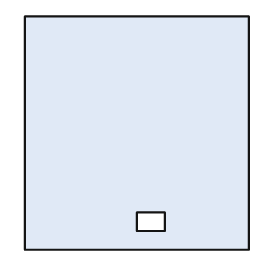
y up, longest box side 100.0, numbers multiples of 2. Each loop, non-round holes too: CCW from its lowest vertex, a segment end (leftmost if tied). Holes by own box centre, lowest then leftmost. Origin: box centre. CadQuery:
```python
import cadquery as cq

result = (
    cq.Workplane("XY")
    .moveTo(-48.0, -50.0)
    .lineTo(48.0, -50.0)
    .lineTo(48.0, 50.0)
    .lineTo(-48.0, 50.0)
    .close()
    .moveTo(0.0, -42.0)
    .lineTo(12.0, -42.0)
    .lineTo(12.0, -34.0)
    .lineTo(0.0, -34.0)
    .close()
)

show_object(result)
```